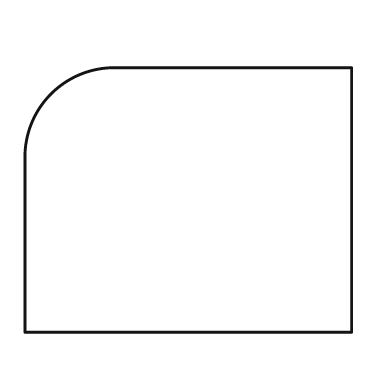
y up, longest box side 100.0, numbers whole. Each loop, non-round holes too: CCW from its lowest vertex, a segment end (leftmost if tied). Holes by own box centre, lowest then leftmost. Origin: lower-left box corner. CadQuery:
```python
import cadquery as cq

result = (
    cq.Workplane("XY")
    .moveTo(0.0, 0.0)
    .lineTo(100.0, 0.0)
    .lineTo(100.0, 81.0)
    .lineTo(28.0, 81.0)
    .threePointArc((8.0, 73.0), (0.0, 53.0))
    .close()
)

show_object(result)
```